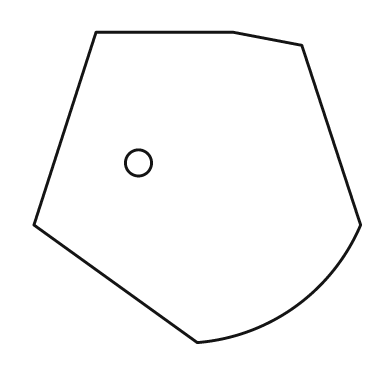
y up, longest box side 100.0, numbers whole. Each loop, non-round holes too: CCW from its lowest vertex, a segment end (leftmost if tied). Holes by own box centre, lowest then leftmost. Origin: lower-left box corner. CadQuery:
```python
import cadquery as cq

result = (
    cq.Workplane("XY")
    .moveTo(50.0, 0.0)
    .threePointArc((80.0, 11.0), (100.0, 36.0))
    .lineTo(82.0, 91.0)
    .lineTo(61.0, 95.0)
    .lineTo(19.0, 95.0)
    .lineTo(0.0, 36.0)
    .close()
    .moveTo(32.0, 55.0)
    .circle(4.0)
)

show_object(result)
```